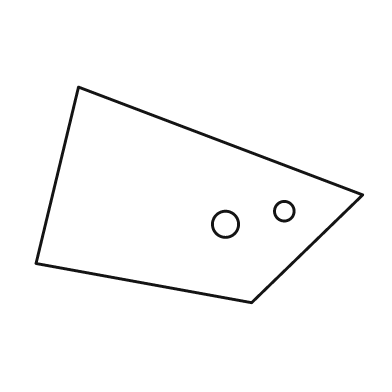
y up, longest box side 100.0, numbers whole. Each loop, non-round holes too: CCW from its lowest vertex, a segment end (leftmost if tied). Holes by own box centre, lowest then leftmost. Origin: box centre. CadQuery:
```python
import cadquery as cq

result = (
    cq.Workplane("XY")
    .moveTo(16.0, -33.0)
    .lineTo(50.0, 0.0)
    .lineTo(-37.0, 33.0)
    .lineTo(-50.0, -21.0)
    .close()
    .moveTo(8.0, -9.0)
    .circle(4.0)
    .moveTo(26.0, -5.0)
    .circle(3.0)
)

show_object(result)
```